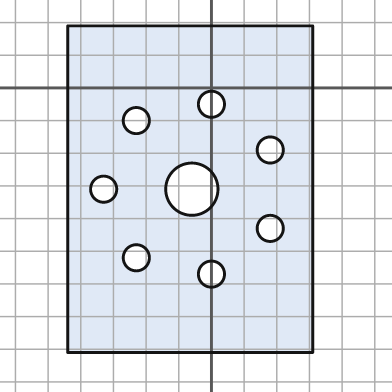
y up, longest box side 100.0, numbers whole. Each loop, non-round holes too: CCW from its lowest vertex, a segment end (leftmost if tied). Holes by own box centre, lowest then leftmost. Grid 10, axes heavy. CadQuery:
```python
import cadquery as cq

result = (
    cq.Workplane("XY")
    .moveTo(-44.0, -81.0)
    .lineTo(31.0, -81.0)
    .lineTo(31.0, 19.0)
    .lineTo(-44.0, 19.0)
    .close()
    .moveTo(0.0, -57.0)
    .circle(4.0)
    .moveTo(-23.0, -52.0)
    .circle(4.0)
    .moveTo(18.0, -43.0)
    .circle(4.0)
    .moveTo(-33.0, -31.0)
    .circle(4.0)
    .moveTo(-6.0, -31.0)
    .circle(8.0)
    .moveTo(18.0, -19.0)
    .circle(4.0)
    .moveTo(-23.0, -10.0)
    .circle(4.0)
    .moveTo(0.0, -5.0)
    .circle(4.0)
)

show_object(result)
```